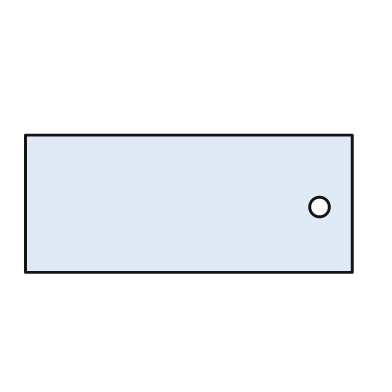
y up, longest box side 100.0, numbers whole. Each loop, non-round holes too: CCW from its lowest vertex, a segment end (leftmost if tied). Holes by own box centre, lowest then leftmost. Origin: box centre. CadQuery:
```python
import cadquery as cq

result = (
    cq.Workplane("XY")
    .moveTo(-50.0, -21.0)
    .lineTo(50.0, -21.0)
    .lineTo(50.0, 21.0)
    .lineTo(-50.0, 21.0)
    .close()
    .moveTo(40.0, -1.0)
    .circle(3.0)
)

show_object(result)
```